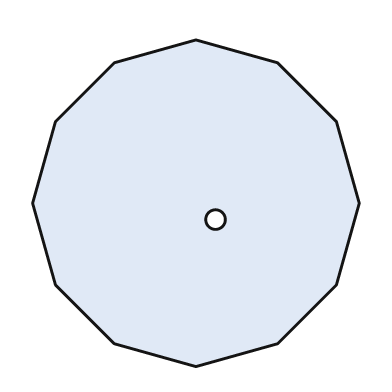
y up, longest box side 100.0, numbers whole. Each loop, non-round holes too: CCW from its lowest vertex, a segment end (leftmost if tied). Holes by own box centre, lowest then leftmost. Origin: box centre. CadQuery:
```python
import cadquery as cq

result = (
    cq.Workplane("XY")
    .moveTo(0.0, -50.0)
    .lineTo(25.0, -43.0)
    .lineTo(43.0, -25.0)
    .lineTo(50.0, 0.0)
    .lineTo(43.0, 25.0)
    .lineTo(25.0, 43.0)
    .lineTo(0.0, 50.0)
    .lineTo(-25.0, 43.0)
    .lineTo(-43.0, 25.0)
    .lineTo(-50.0, 0.0)
    .lineTo(-43.0, -25.0)
    .lineTo(-25.0, -43.0)
    .close()
    .moveTo(6.0, -5.0)
    .circle(3.0)
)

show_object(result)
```